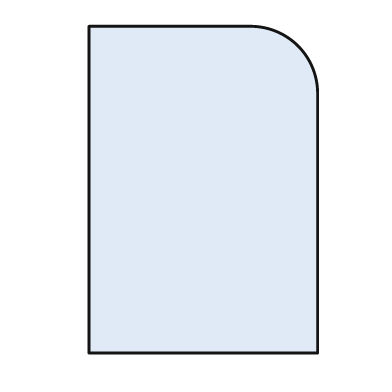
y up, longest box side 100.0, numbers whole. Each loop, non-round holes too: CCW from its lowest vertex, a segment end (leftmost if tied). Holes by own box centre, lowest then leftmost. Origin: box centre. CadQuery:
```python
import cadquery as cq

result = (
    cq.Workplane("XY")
    .moveTo(-35.0, -50.0)
    .lineTo(35.0, -50.0)
    .lineTo(35.0, 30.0)
    .threePointArc((29.0, 44.0), (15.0, 50.0))
    .lineTo(-35.0, 50.0)
    .close()
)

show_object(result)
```